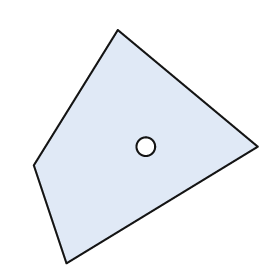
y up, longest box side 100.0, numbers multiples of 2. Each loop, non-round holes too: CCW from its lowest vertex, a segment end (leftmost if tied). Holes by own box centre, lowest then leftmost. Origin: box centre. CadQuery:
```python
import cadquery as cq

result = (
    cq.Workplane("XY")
    .moveTo(-34.0, -50.0)
    .lineTo(48.0, 0.0)
    .lineTo(-12.0, 50.0)
    .lineTo(-48.0, -8.0)
    .close()
    .moveTo(0.0, 0.0)
    .circle(4.0)
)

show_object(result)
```